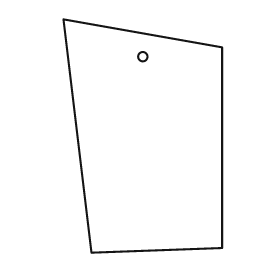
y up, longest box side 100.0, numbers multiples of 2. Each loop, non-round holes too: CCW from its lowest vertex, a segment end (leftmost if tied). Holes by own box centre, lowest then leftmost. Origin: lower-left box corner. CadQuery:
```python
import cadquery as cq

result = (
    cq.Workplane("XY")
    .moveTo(12.0, 0.0)
    .lineTo(68.0, 2.0)
    .lineTo(68.0, 88.0)
    .lineTo(0.0, 100.0)
    .close()
    .moveTo(34.0, 84.0)
    .circle(2.0)
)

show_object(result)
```